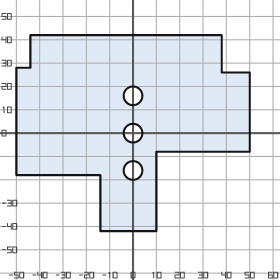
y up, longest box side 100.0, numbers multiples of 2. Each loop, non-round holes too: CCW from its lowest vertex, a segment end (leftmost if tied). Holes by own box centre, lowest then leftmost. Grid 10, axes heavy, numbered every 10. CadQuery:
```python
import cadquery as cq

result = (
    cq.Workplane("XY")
    .moveTo(-14.0, -42.0)
    .lineTo(10.0, -42.0)
    .lineTo(10.0, -8.0)
    .lineTo(50.0, -8.0)
    .lineTo(50.0, 26.0)
    .lineTo(38.0, 26.0)
    .lineTo(38.0, 42.0)
    .lineTo(-44.0, 42.0)
    .lineTo(-44.0, 28.0)
    .lineTo(-50.0, 28.0)
    .lineTo(-50.0, -18.0)
    .lineTo(-14.0, -18.0)
    .close()
    .moveTo(0.0, -16.0)
    .circle(4.0)
    .moveTo(0.0, 0.0)
    .circle(4.0)
    .moveTo(0.0, 16.0)
    .circle(4.0)
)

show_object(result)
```